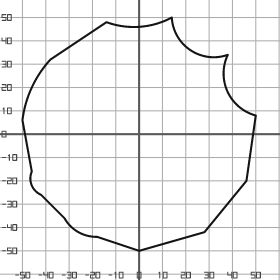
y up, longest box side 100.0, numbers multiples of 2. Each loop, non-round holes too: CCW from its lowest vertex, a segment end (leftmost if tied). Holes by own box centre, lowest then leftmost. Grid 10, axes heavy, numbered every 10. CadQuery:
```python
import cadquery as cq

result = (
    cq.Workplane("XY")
    .moveTo(0.0, -50.0)
    .lineTo(28.0, -42.0)
    .lineTo(46.0, -20.0)
    .lineTo(50.0, 8.0)
    .threePointArc((38.0, 18.0), (38.0, 34.0))
    .threePointArc((22.0, 36.0), (14.0, 50.0))
    .threePointArc((0.0, 46.0), (-14.0, 48.0))
    .lineTo(-38.0, 32.0)
    .threePointArc((-46.0, 20.0), (-50.0, 6.0))
    .lineTo(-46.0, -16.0)
    .threePointArc((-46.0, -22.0), (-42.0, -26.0))
    .lineTo(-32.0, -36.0)
    .threePointArc((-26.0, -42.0), (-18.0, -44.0))
    .close()
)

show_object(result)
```